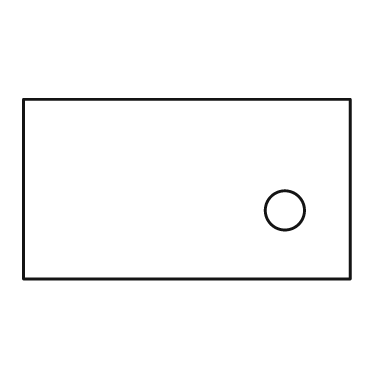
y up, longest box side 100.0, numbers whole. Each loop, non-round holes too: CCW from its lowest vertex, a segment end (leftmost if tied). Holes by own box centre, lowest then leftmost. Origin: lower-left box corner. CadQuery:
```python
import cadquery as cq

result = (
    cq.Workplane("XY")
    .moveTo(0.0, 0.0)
    .lineTo(100.0, 0.0)
    .lineTo(100.0, 55.0)
    .lineTo(0.0, 55.0)
    .close()
    .moveTo(80.0, 21.0)
    .circle(6.0)
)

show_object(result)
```